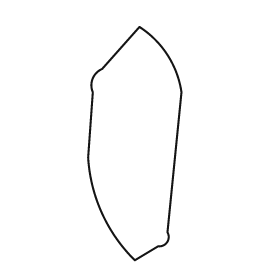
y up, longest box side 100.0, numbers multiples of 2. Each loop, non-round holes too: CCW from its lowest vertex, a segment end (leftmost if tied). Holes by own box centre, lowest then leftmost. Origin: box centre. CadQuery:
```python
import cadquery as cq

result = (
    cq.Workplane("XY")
    .moveTo(0.0, -50.0)
    .lineTo(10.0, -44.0)
    .threePointArc((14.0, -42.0), (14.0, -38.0))
    .lineTo(20.0, 22.0)
    .threePointArc((14.0, 38.0), (2.0, 50.0))
    .lineTo(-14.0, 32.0)
    .threePointArc((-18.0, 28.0), (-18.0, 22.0))
    .lineTo(-20.0, -6.0)
    .threePointArc((-14.0, -30.0), (0.0, -50.0))
    .close()
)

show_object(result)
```